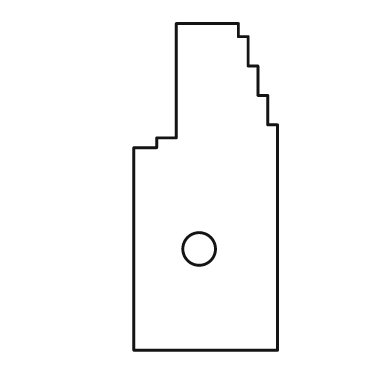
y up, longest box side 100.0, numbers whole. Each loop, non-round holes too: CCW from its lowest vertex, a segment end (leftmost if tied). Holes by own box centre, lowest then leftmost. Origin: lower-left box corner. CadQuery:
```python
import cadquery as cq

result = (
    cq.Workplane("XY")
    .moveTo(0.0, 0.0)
    .lineTo(44.0, 0.0)
    .lineTo(44.0, 69.0)
    .lineTo(41.0, 69.0)
    .lineTo(41.0, 78.0)
    .lineTo(38.0, 78.0)
    .lineTo(38.0, 87.0)
    .lineTo(35.0, 87.0)
    .lineTo(35.0, 96.0)
    .lineTo(32.0, 96.0)
    .lineTo(32.0, 100.0)
    .lineTo(13.0, 100.0)
    .lineTo(13.0, 65.0)
    .lineTo(7.0, 65.0)
    .lineTo(7.0, 62.0)
    .lineTo(0.0, 62.0)
    .close()
    .moveTo(20.0, 31.0)
    .circle(5.0)
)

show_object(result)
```